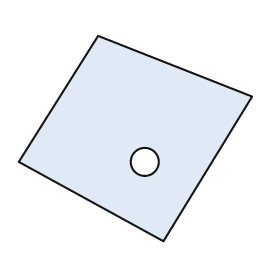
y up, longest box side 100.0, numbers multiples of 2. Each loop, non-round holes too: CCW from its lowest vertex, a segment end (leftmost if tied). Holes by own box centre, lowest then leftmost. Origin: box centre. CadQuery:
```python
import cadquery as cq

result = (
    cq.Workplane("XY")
    .moveTo(12.0, -44.0)
    .lineTo(50.0, 18.0)
    .lineTo(-16.0, 44.0)
    .lineTo(-50.0, -10.0)
    .close()
    .moveTo(4.0, -10.0)
    .circle(6.0)
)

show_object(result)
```